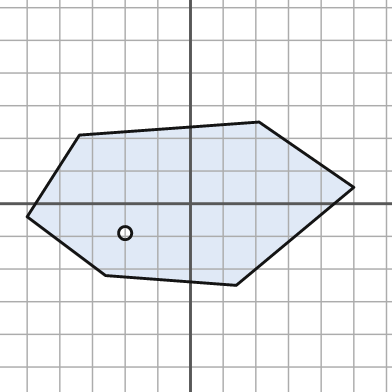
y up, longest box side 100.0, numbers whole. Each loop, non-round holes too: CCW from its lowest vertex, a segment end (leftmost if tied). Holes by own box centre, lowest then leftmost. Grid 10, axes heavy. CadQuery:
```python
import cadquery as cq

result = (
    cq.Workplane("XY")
    .moveTo(14.0, -25.0)
    .lineTo(50.0, 5.0)
    .lineTo(21.0, 25.0)
    .lineTo(-34.0, 21.0)
    .lineTo(-50.0, -4.0)
    .lineTo(-26.0, -22.0)
    .close()
    .moveTo(-20.0, -9.0)
    .circle(2.0)
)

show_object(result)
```